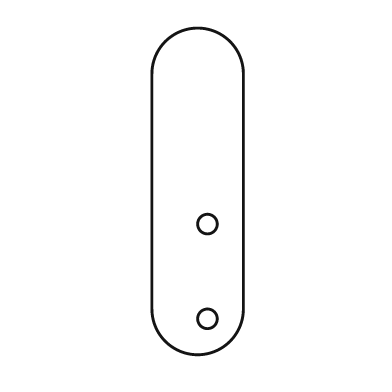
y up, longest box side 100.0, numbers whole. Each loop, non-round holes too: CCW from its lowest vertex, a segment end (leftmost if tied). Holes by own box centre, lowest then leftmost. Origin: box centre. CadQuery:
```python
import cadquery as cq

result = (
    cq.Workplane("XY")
    .moveTo(-14.0, -36.0)
    .threePointArc((0.0, -50.0), (14.0, -36.0))
    .lineTo(14.0, 36.0)
    .threePointArc((0.0, 50.0), (-14.0, 36.0))
    .close()
    .moveTo(3.0, -39.0)
    .circle(3.0)
    .moveTo(3.0, -10.0)
    .circle(3.0)
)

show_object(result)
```